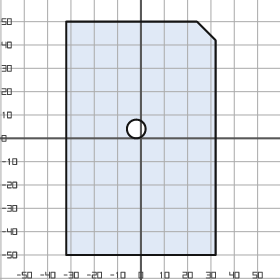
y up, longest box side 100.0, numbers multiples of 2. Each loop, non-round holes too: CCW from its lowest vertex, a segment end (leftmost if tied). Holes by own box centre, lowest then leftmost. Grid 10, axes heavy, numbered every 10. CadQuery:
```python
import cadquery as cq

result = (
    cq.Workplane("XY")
    .moveTo(-32.0, -50.0)
    .lineTo(32.0, -50.0)
    .lineTo(32.0, 42.0)
    .lineTo(24.0, 50.0)
    .lineTo(-32.0, 50.0)
    .close()
    .moveTo(-2.0, 4.0)
    .circle(4.0)
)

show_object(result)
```